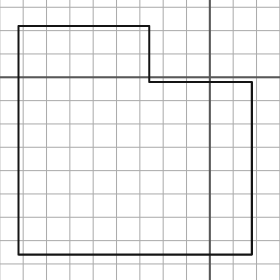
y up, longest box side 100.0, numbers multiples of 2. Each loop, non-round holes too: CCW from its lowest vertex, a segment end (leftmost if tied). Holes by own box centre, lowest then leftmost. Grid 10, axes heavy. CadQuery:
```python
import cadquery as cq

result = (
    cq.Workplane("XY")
    .moveTo(-82.0, -76.0)
    .lineTo(18.0, -76.0)
    .lineTo(18.0, -2.0)
    .lineTo(-26.0, -2.0)
    .lineTo(-26.0, 22.0)
    .lineTo(-82.0, 22.0)
    .close()
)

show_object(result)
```